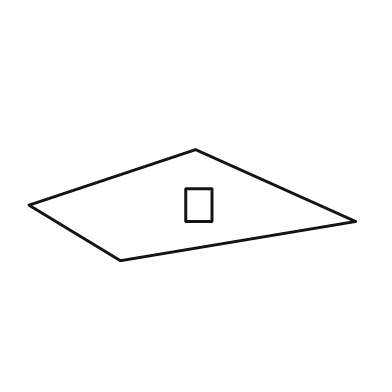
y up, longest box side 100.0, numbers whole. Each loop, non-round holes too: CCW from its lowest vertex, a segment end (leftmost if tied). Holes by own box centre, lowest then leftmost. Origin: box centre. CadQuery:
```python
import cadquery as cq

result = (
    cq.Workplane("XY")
    .moveTo(-22.0, -17.0)
    .lineTo(50.0, -5.0)
    .lineTo(1.0, 17.0)
    .lineTo(-50.0, 0.0)
    .close()
    .moveTo(-2.0, -5.0)
    .lineTo(6.0, -5.0)
    .lineTo(6.0, 5.0)
    .lineTo(-2.0, 5.0)
    .close()
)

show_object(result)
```